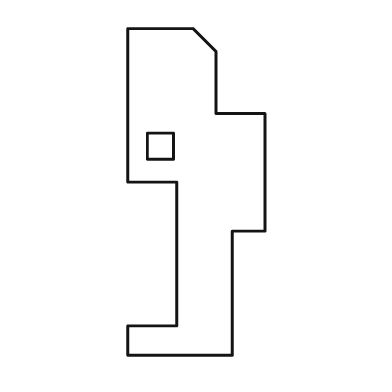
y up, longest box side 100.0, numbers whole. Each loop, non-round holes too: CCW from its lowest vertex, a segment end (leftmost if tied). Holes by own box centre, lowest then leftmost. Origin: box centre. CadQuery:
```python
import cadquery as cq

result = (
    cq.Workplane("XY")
    .moveTo(-21.0, -50.0)
    .lineTo(11.0, -50.0)
    .lineTo(11.0, -12.0)
    .lineTo(21.0, -12.0)
    .lineTo(21.0, 24.0)
    .lineTo(6.0, 24.0)
    .lineTo(6.0, 43.0)
    .lineTo(-1.0, 50.0)
    .lineTo(-21.0, 50.0)
    .lineTo(-21.0, 3.0)
    .lineTo(-6.0, 3.0)
    .lineTo(-6.0, -41.0)
    .lineTo(-21.0, -41.0)
    .close()
    .moveTo(-15.0, 10.0)
    .lineTo(-7.0, 10.0)
    .lineTo(-7.0, 18.0)
    .lineTo(-15.0, 18.0)
    .close()
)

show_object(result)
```